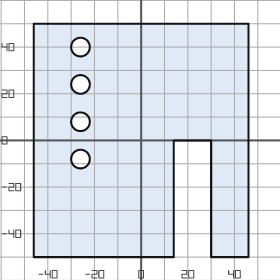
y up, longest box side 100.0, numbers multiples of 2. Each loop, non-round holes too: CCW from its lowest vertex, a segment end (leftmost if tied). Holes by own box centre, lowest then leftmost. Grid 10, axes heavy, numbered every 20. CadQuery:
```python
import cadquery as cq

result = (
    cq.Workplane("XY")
    .moveTo(-46.0, -50.0)
    .lineTo(14.0, -50.0)
    .lineTo(14.0, 0.0)
    .lineTo(30.0, 0.0)
    .lineTo(30.0, -50.0)
    .lineTo(46.0, -50.0)
    .lineTo(46.0, 50.0)
    .lineTo(-46.0, 50.0)
    .close()
    .moveTo(-26.0, -8.0)
    .circle(4.0)
    .moveTo(-26.0, 8.0)
    .circle(4.0)
    .moveTo(-26.0, 24.0)
    .circle(4.0)
    .moveTo(-26.0, 40.0)
    .circle(4.0)
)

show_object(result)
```